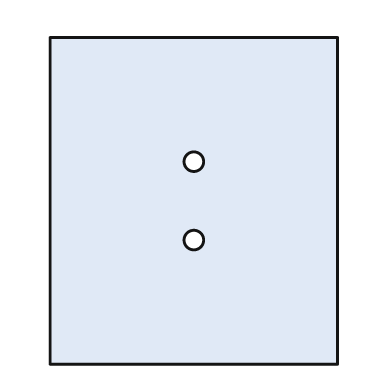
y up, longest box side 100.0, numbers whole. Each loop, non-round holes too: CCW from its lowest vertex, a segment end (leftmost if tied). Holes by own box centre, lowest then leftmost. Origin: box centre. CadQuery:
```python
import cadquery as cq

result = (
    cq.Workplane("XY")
    .moveTo(-44.0, -50.0)
    .lineTo(44.0, -50.0)
    .lineTo(44.0, 50.0)
    .lineTo(-44.0, 50.0)
    .close()
    .moveTo(0.0, -12.0)
    .circle(3.0)
    .moveTo(0.0, 12.0)
    .circle(3.0)
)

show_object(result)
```